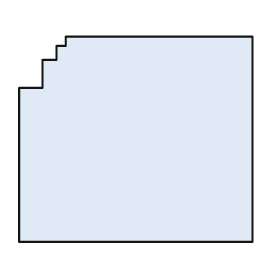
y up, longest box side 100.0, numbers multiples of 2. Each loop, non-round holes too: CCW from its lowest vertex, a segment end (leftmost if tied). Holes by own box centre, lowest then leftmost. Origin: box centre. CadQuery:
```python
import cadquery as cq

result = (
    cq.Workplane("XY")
    .moveTo(-50.0, -44.0)
    .lineTo(50.0, -44.0)
    .lineTo(50.0, 44.0)
    .lineTo(-30.0, 44.0)
    .lineTo(-30.0, 40.0)
    .lineTo(-34.0, 40.0)
    .lineTo(-34.0, 34.0)
    .lineTo(-40.0, 34.0)
    .lineTo(-40.0, 22.0)
    .lineTo(-50.0, 22.0)
    .close()
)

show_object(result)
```